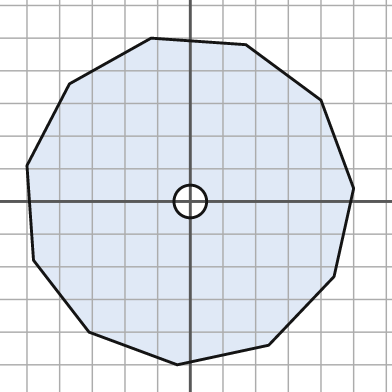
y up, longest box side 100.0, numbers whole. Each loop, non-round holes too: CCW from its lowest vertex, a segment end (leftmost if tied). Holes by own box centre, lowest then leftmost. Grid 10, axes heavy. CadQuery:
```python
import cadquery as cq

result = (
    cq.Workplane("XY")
    .moveTo(-4.0, -50.0)
    .lineTo(24.0, -44.0)
    .lineTo(44.0, -23.0)
    .lineTo(50.0, 4.0)
    .lineTo(40.0, 31.0)
    .lineTo(17.0, 48.0)
    .lineTo(-12.0, 50.0)
    .lineTo(-37.0, 36.0)
    .lineTo(-50.0, 11.0)
    .lineTo(-48.0, -18.0)
    .lineTo(-31.0, -40.0)
    .close()
    .moveTo(0.0, 0.0)
    .circle(5.0)
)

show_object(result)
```